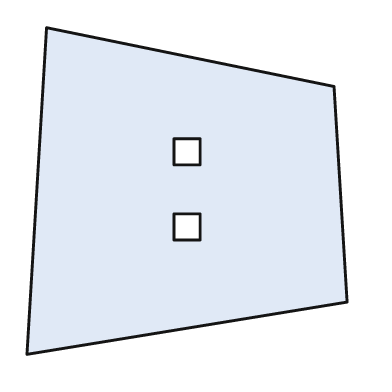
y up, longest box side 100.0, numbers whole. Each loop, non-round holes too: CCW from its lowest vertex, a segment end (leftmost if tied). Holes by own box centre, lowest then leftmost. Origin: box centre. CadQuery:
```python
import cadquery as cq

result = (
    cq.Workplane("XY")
    .moveTo(-49.0, -50.0)
    .lineTo(49.0, -34.0)
    .lineTo(45.0, 32.0)
    .lineTo(-43.0, 50.0)
    .close()
    .moveTo(-4.0, -15.0)
    .lineTo(4.0, -15.0)
    .lineTo(4.0, -7.0)
    .lineTo(-4.0, -7.0)
    .close()
    .moveTo(-4.0, 8.0)
    .lineTo(4.0, 8.0)
    .lineTo(4.0, 16.0)
    .lineTo(-4.0, 16.0)
    .close()
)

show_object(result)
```